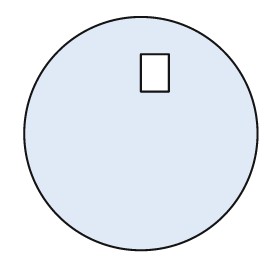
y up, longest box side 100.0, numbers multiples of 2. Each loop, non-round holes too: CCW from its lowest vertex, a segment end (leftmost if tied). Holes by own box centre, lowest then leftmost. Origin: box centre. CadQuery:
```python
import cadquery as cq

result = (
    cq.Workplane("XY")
    .moveTo(0.0, 0.0)
    .circle(50.0)
    .moveTo(0.0, 18.0)
    .lineTo(12.0, 18.0)
    .lineTo(12.0, 34.0)
    .lineTo(0.0, 34.0)
    .close()
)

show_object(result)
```